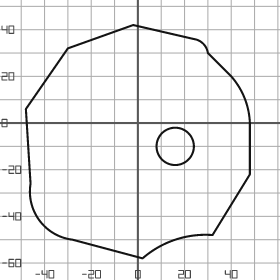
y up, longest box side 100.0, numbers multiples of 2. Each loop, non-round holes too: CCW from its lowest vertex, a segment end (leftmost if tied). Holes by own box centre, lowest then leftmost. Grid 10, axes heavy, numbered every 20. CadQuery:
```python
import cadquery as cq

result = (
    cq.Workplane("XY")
    .moveTo(2.0, -58.0)
    .threePointArc((16.0, -50.0), (32.0, -48.0))
    .lineTo(48.0, -22.0)
    .lineTo(48.0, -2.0)
    .threePointArc((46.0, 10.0), (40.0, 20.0))
    .lineTo(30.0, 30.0)
    .threePointArc((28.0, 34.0), (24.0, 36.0))
    .lineTo(-2.0, 42.0)
    .lineTo(-30.0, 32.0)
    .lineTo(-48.0, 6.0)
    .lineTo(-46.0, -26.0)
    .threePointArc((-42.0, -42.0), (-28.0, -50.0))
    .close()
    .moveTo(16.0, -10.0)
    .circle(8.0)
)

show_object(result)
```